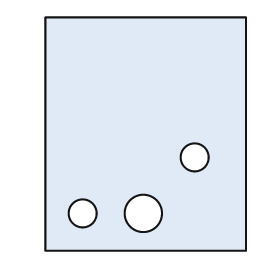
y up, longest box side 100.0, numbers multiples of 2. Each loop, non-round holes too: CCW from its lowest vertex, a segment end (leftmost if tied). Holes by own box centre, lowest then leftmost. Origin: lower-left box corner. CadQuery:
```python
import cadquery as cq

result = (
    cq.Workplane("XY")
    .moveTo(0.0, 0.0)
    .lineTo(86.0, 0.0)
    .lineTo(86.0, 100.0)
    .lineTo(0.0, 100.0)
    .close()
    .moveTo(16.0, 16.0)
    .circle(6.0)
    .moveTo(42.0, 16.0)
    .circle(8.0)
    .moveTo(64.0, 40.0)
    .circle(6.0)
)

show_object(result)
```